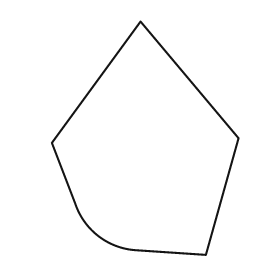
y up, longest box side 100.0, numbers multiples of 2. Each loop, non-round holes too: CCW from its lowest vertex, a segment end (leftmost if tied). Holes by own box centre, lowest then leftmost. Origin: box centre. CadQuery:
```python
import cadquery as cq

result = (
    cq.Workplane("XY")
    .moveTo(26.0, -50.0)
    .lineTo(40.0, 0.0)
    .lineTo(-2.0, 50.0)
    .lineTo(-40.0, -2.0)
    .lineTo(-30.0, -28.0)
    .threePointArc((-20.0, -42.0), (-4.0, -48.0))
    .close()
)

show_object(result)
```